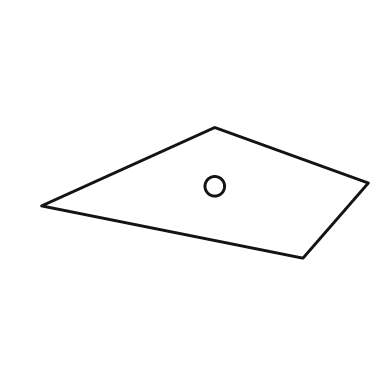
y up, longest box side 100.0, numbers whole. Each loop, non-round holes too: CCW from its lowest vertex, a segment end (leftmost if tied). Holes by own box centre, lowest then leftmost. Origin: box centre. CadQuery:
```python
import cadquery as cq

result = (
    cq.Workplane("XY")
    .moveTo(30.0, -20.0)
    .lineTo(50.0, 3.0)
    .lineTo(3.0, 20.0)
    .lineTo(-50.0, -4.0)
    .close()
    .moveTo(3.0, 2.0)
    .circle(3.0)
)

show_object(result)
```